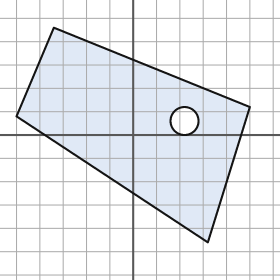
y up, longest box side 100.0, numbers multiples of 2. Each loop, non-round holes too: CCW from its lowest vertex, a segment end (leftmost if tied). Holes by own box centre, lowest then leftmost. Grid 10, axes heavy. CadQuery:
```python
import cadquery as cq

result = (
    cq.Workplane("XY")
    .moveTo(32.0, -46.0)
    .lineTo(50.0, 12.0)
    .lineTo(-34.0, 46.0)
    .lineTo(-50.0, 8.0)
    .close()
    .moveTo(22.0, 6.0)
    .circle(6.0)
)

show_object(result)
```